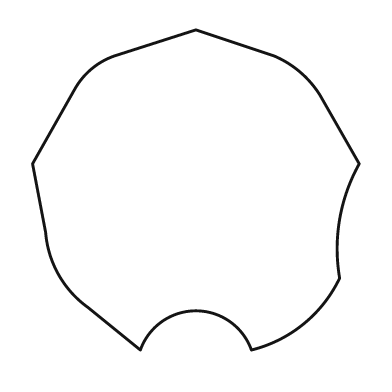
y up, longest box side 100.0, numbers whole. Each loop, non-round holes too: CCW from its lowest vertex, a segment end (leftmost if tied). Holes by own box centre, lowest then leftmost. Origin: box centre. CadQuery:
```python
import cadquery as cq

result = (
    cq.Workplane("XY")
    .moveTo(-17.0, -49.0)
    .threePointArc((0.0, -37.0), (17.0, -49.0))
    .threePointArc((33.0, -41.0), (44.0, -27.0))
    .threePointArc((44.0, -9.0), (50.0, 8.0))
    .lineTo(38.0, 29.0)
    .threePointArc((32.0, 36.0), (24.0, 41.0))
    .lineTo(0.0, 49.0)
    .lineTo(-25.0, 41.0)
    .threePointArc((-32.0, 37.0), (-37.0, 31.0))
    .lineTo(-50.0, 8.0)
    .lineTo(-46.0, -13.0)
    .threePointArc((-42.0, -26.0), (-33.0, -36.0))
    .close()
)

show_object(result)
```